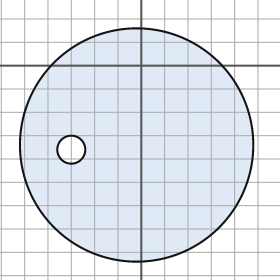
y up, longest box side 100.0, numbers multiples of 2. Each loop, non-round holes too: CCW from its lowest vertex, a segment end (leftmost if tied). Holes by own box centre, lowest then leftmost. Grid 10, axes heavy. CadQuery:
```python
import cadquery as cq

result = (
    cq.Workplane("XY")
    .moveTo(-2.0, -34.0)
    .circle(50.0)
    .moveTo(-30.0, -36.0)
    .circle(6.0)
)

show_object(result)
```